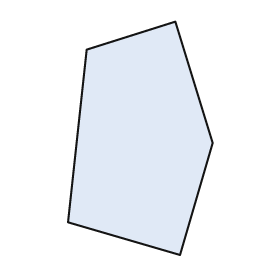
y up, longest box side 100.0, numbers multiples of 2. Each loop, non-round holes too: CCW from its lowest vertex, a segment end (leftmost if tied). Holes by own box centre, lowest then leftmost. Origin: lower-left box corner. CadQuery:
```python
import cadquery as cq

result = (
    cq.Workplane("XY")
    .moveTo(48.0, 0.0)
    .lineTo(62.0, 48.0)
    .lineTo(46.0, 100.0)
    .lineTo(8.0, 88.0)
    .lineTo(0.0, 14.0)
    .close()
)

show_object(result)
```